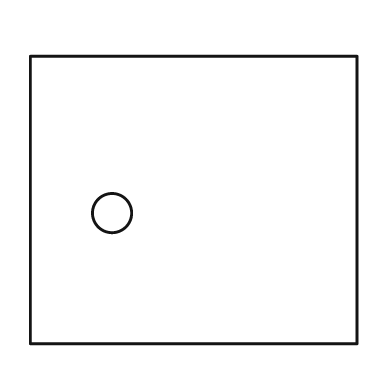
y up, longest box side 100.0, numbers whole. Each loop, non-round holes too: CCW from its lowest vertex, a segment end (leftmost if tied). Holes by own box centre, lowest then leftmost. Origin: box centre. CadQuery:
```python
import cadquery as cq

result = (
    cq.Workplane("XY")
    .moveTo(-50.0, -44.0)
    .lineTo(50.0, -44.0)
    .lineTo(50.0, 44.0)
    .lineTo(-50.0, 44.0)
    .close()
    .moveTo(-25.0, -4.0)
    .circle(6.0)
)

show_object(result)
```